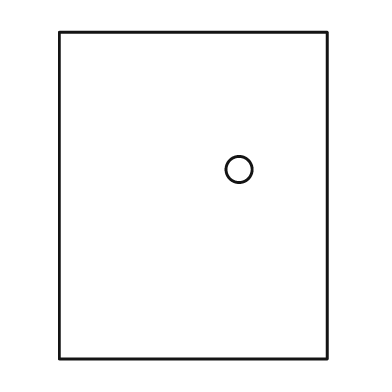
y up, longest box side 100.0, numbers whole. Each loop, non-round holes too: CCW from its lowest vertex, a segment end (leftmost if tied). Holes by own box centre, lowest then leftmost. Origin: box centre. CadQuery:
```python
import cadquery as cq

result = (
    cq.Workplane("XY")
    .moveTo(-41.0, -50.0)
    .lineTo(41.0, -50.0)
    .lineTo(41.0, 50.0)
    .lineTo(-41.0, 50.0)
    .close()
    .moveTo(14.0, 8.0)
    .circle(4.0)
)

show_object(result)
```